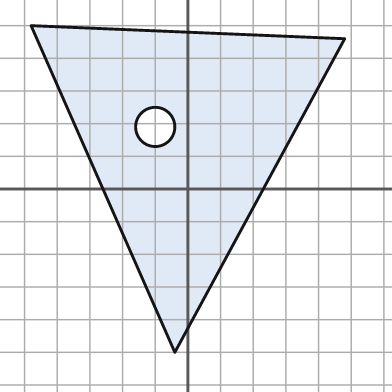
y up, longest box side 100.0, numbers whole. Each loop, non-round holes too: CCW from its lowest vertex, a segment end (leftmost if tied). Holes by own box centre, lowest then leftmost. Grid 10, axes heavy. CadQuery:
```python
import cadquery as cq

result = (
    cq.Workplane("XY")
    .moveTo(-4.0, -50.0)
    .lineTo(48.0, 46.0)
    .lineTo(-48.0, 50.0)
    .close()
    .moveTo(-10.0, 19.0)
    .circle(6.0)
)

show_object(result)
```